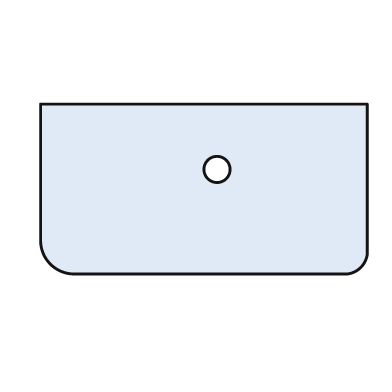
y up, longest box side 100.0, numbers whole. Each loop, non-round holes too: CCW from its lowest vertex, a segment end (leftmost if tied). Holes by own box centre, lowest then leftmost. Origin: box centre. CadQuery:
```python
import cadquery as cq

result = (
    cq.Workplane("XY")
    .moveTo(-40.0, -26.0)
    .lineTo(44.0, -26.0)
    .threePointArc((48.0, -24.0), (50.0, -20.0))
    .lineTo(50.0, 26.0)
    .lineTo(-50.0, 26.0)
    .lineTo(-50.0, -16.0)
    .threePointArc((-47.0, -23.0), (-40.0, -26.0))
    .close()
    .moveTo(4.0, 6.0)
    .circle(4.0)
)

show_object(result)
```